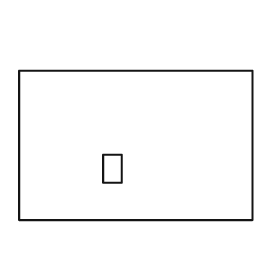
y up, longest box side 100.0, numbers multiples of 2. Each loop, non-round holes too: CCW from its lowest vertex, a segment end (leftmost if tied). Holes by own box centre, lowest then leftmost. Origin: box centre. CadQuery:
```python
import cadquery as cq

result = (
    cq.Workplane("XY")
    .moveTo(-50.0, -32.0)
    .lineTo(50.0, -32.0)
    .lineTo(50.0, 32.0)
    .lineTo(-50.0, 32.0)
    .close()
    .moveTo(-14.0, -16.0)
    .lineTo(-6.0, -16.0)
    .lineTo(-6.0, -4.0)
    .lineTo(-14.0, -4.0)
    .close()
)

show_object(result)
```